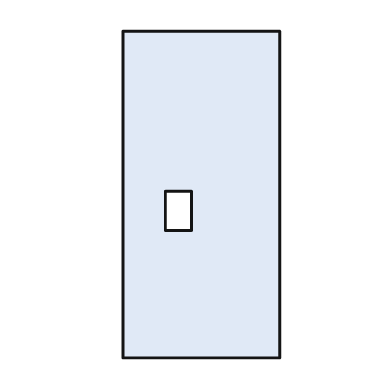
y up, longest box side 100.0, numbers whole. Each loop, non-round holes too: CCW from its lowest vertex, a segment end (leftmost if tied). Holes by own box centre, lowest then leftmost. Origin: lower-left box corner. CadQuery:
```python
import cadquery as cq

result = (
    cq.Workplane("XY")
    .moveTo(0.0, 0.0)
    .lineTo(48.0, 0.0)
    .lineTo(48.0, 100.0)
    .lineTo(0.0, 100.0)
    .close()
    .moveTo(13.0, 39.0)
    .lineTo(21.0, 39.0)
    .lineTo(21.0, 51.0)
    .lineTo(13.0, 51.0)
    .close()
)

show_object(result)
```